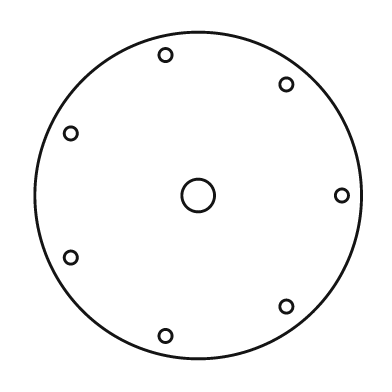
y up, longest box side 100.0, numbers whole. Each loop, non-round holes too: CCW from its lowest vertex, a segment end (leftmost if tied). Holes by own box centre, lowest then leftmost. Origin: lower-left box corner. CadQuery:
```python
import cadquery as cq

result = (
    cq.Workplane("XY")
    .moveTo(50.0, 50.0)
    .circle(50.0)
    .moveTo(40.0, 7.0)
    .circle(2.0)
    .moveTo(77.0, 16.0)
    .circle(2.0)
    .moveTo(11.0, 31.0)
    .circle(2.0)
    .moveTo(50.0, 50.0)
    .circle(5.0)
    .moveTo(94.0, 50.0)
    .circle(2.0)
    .moveTo(11.0, 69.0)
    .circle(2.0)
    .moveTo(77.0, 84.0)
    .circle(2.0)
    .moveTo(40.0, 93.0)
    .circle(2.0)
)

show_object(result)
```